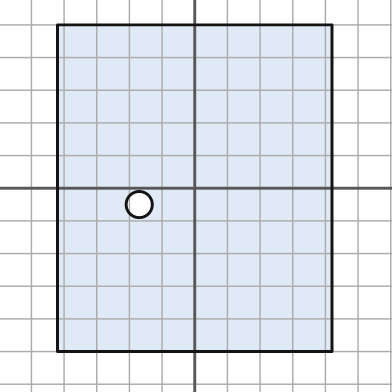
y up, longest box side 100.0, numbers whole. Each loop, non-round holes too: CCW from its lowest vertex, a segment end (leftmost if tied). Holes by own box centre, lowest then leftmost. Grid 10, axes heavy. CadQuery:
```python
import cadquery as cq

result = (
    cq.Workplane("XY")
    .moveTo(-42.0, -50.0)
    .lineTo(42.0, -50.0)
    .lineTo(42.0, 50.0)
    .lineTo(-42.0, 50.0)
    .close()
    .moveTo(-17.0, -5.0)
    .circle(4.0)
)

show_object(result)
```